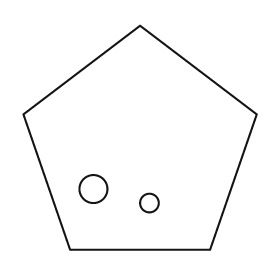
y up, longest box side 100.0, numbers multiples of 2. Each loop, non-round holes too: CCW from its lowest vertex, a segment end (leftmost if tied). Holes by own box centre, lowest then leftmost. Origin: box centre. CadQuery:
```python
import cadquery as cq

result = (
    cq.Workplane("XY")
    .moveTo(-30.0, -48.0)
    .lineTo(30.0, -48.0)
    .lineTo(50.0, 10.0)
    .lineTo(0.0, 48.0)
    .lineTo(-50.0, 10.0)
    .close()
    .moveTo(4.0, -28.0)
    .circle(4.0)
    .moveTo(-20.0, -22.0)
    .circle(6.0)
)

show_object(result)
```